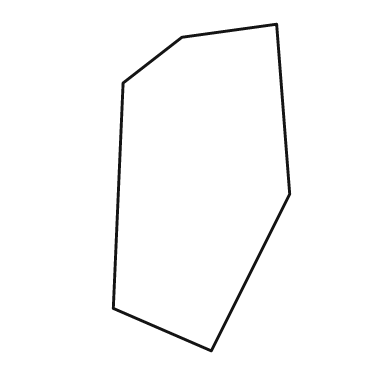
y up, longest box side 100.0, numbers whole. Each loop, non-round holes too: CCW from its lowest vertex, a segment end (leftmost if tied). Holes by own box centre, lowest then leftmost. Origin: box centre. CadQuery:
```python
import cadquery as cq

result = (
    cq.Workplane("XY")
    .moveTo(3.0, -50.0)
    .lineTo(27.0, -2.0)
    .lineTo(23.0, 50.0)
    .lineTo(-6.0, 46.0)
    .lineTo(-24.0, 32.0)
    .lineTo(-27.0, -37.0)
    .close()
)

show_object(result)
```